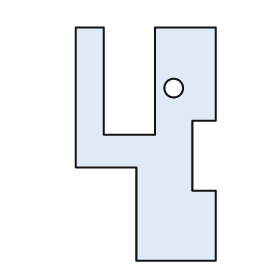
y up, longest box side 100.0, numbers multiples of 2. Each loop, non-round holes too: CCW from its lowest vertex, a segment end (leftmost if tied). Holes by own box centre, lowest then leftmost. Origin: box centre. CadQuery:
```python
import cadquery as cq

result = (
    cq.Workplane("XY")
    .moveTo(-4.0, -50.0)
    .lineTo(30.0, -50.0)
    .lineTo(30.0, -20.0)
    .lineTo(20.0, -20.0)
    .lineTo(20.0, 10.0)
    .lineTo(30.0, 10.0)
    .lineTo(30.0, 50.0)
    .lineTo(4.0, 50.0)
    .lineTo(4.0, 4.0)
    .lineTo(-18.0, 4.0)
    .lineTo(-18.0, 50.0)
    .lineTo(-30.0, 50.0)
    .lineTo(-30.0, -10.0)
    .lineTo(-4.0, -10.0)
    .close()
    .moveTo(12.0, 24.0)
    .circle(4.0)
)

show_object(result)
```